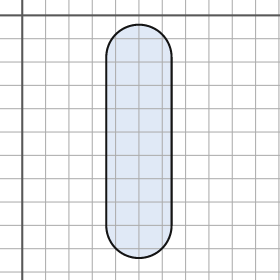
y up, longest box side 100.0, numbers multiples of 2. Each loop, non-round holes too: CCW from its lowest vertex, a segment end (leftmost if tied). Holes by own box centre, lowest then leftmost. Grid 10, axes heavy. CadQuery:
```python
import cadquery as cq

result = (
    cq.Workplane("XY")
    .moveTo(36.0, -90.0)
    .threePointArc((50.0, -104.0), (64.0, -90.0))
    .lineTo(64.0, -18.0)
    .threePointArc((50.0, -4.0), (36.0, -18.0))
    .close()
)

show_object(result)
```